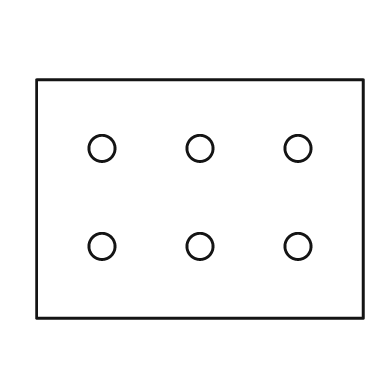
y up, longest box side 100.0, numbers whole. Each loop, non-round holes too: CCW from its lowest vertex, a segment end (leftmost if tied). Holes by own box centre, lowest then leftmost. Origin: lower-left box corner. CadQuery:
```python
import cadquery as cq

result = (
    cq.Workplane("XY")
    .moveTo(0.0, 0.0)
    .lineTo(100.0, 0.0)
    .lineTo(100.0, 73.0)
    .lineTo(0.0, 73.0)
    .close()
    .moveTo(20.0, 22.0)
    .circle(4.0)
    .moveTo(50.0, 22.0)
    .circle(4.0)
    .moveTo(80.0, 22.0)
    .circle(4.0)
    .moveTo(20.0, 52.0)
    .circle(4.0)
    .moveTo(50.0, 52.0)
    .circle(4.0)
    .moveTo(80.0, 52.0)
    .circle(4.0)
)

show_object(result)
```